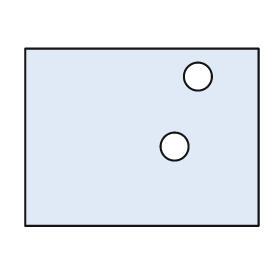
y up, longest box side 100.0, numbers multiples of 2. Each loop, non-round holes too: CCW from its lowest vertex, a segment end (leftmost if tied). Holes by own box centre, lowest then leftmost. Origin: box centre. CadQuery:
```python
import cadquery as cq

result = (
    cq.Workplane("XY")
    .moveTo(-50.0, -38.0)
    .lineTo(50.0, -38.0)
    .lineTo(50.0, 38.0)
    .lineTo(-50.0, 38.0)
    .close()
    .moveTo(14.0, -4.0)
    .circle(6.0)
    .moveTo(24.0, 26.0)
    .circle(6.0)
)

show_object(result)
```